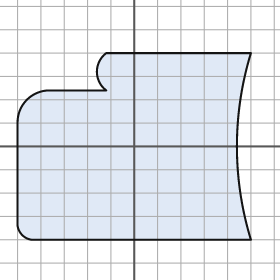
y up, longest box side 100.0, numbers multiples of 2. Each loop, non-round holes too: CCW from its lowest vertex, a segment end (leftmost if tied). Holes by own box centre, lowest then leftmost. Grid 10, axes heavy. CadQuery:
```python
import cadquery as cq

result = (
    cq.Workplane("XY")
    .moveTo(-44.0, -40.0)
    .lineTo(50.0, -40.0)
    .threePointArc((44.0, 0.0), (50.0, 40.0))
    .lineTo(-12.0, 40.0)
    .threePointArc((-16.0, 32.0), (-12.0, 24.0))
    .lineTo(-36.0, 24.0)
    .threePointArc((-46.0, 20.0), (-50.0, 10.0))
    .lineTo(-50.0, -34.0)
    .threePointArc((-48.0, -38.0), (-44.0, -40.0))
    .close()
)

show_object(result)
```